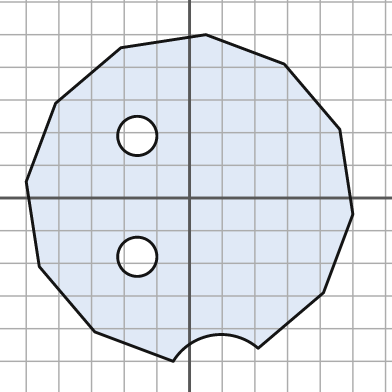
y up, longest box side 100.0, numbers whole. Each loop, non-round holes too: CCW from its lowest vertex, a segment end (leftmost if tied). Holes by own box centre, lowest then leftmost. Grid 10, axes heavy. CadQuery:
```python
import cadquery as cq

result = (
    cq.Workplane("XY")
    .moveTo(-5.0, -50.0)
    .threePointArc((7.0, -42.0), (21.0, -46.0))
    .lineTo(41.0, -29.0)
    .lineTo(50.0, -5.0)
    .lineTo(46.0, 21.0)
    .lineTo(29.0, 41.0)
    .lineTo(5.0, 50.0)
    .lineTo(-21.0, 46.0)
    .lineTo(-41.0, 29.0)
    .lineTo(-50.0, 5.0)
    .lineTo(-46.0, -21.0)
    .lineTo(-29.0, -41.0)
    .close()
    .moveTo(-16.0, -18.0)
    .circle(6.0)
    .moveTo(-16.0, 19.0)
    .circle(6.0)
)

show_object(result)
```